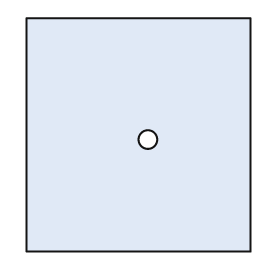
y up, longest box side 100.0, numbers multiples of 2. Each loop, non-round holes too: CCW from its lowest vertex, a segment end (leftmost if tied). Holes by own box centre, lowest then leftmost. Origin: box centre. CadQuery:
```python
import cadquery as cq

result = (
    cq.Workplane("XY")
    .moveTo(-48.0, -50.0)
    .lineTo(48.0, -50.0)
    .lineTo(48.0, 50.0)
    .lineTo(-48.0, 50.0)
    .close()
    .moveTo(4.0, -2.0)
    .circle(4.0)
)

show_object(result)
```